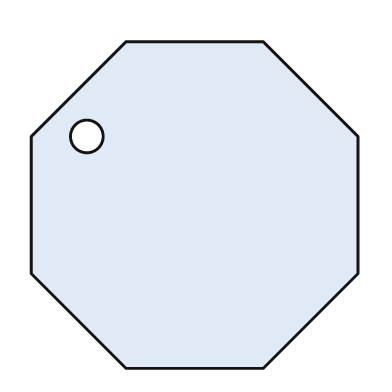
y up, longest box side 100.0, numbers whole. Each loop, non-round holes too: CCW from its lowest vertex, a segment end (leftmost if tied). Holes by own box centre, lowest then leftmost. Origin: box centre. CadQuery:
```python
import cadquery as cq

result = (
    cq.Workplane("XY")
    .moveTo(-21.0, -50.0)
    .lineTo(21.0, -50.0)
    .lineTo(50.0, -21.0)
    .lineTo(50.0, 21.0)
    .lineTo(21.0, 50.0)
    .lineTo(-21.0, 50.0)
    .lineTo(-50.0, 21.0)
    .lineTo(-50.0, -21.0)
    .close()
    .moveTo(-33.0, 21.0)
    .circle(5.0)
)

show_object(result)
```